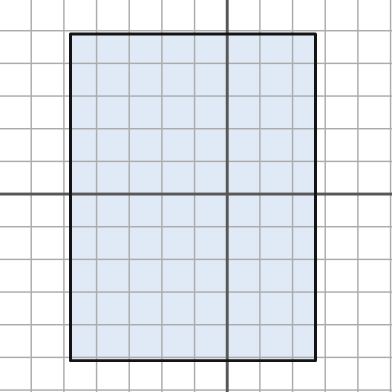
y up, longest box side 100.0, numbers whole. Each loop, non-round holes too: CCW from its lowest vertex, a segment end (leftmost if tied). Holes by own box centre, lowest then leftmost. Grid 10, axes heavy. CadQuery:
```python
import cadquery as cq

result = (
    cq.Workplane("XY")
    .moveTo(-48.0, -51.0)
    .lineTo(27.0, -51.0)
    .lineTo(27.0, 49.0)
    .lineTo(-48.0, 49.0)
    .close()
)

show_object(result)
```